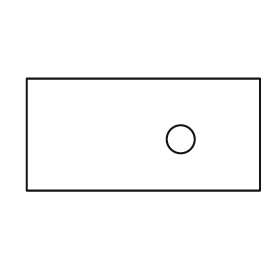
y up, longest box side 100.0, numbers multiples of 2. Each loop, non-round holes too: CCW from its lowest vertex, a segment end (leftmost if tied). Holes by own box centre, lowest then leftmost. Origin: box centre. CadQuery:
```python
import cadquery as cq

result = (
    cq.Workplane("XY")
    .moveTo(-50.0, -24.0)
    .lineTo(50.0, -24.0)
    .lineTo(50.0, 24.0)
    .lineTo(-50.0, 24.0)
    .close()
    .moveTo(16.0, -2.0)
    .circle(6.0)
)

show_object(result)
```